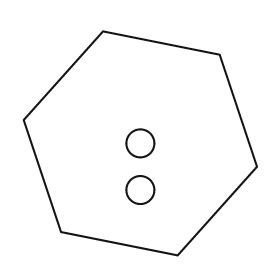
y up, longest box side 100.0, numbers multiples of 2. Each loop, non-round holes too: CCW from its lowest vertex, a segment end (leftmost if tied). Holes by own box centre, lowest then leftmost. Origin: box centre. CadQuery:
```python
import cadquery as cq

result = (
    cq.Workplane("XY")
    .moveTo(16.0, -48.0)
    .lineTo(50.0, -10.0)
    .lineTo(34.0, 38.0)
    .lineTo(-16.0, 48.0)
    .lineTo(-50.0, 10.0)
    .lineTo(-34.0, -38.0)
    .close()
    .moveTo(0.0, -20.0)
    .circle(6.0)
    .moveTo(0.0, 0.0)
    .circle(6.0)
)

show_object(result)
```